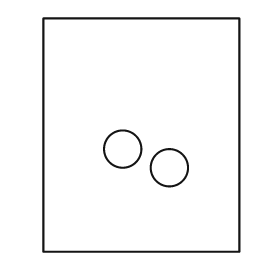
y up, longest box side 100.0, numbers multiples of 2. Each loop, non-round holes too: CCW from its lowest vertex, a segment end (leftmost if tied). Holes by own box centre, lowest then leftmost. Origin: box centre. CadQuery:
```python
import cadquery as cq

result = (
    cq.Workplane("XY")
    .moveTo(-42.0, -50.0)
    .lineTo(42.0, -50.0)
    .lineTo(42.0, 50.0)
    .lineTo(-42.0, 50.0)
    .close()
    .moveTo(12.0, -14.0)
    .circle(8.0)
    .moveTo(-8.0, -6.0)
    .circle(8.0)
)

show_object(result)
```